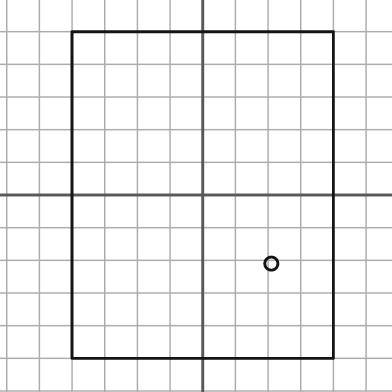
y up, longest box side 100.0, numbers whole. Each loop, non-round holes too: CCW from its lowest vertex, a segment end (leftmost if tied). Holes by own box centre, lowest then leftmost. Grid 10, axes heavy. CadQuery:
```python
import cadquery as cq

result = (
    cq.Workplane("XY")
    .moveTo(-40.0, -50.0)
    .lineTo(40.0, -50.0)
    .lineTo(40.0, 50.0)
    .lineTo(-40.0, 50.0)
    .close()
    .moveTo(21.0, -21.0)
    .circle(2.0)
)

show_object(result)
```